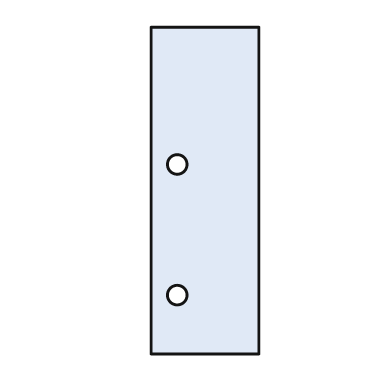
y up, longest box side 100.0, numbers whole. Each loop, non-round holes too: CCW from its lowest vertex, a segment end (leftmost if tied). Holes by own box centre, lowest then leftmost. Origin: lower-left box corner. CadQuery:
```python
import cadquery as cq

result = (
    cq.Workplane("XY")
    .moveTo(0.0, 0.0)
    .lineTo(33.0, 0.0)
    .lineTo(33.0, 100.0)
    .lineTo(0.0, 100.0)
    .close()
    .moveTo(8.0, 18.0)
    .circle(3.0)
    .moveTo(8.0, 58.0)
    .circle(3.0)
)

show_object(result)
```